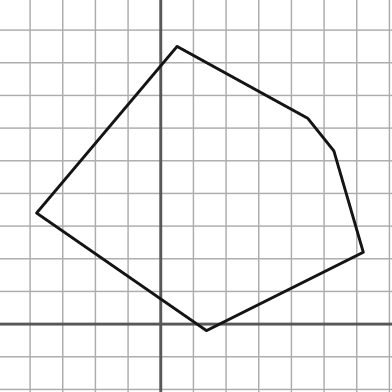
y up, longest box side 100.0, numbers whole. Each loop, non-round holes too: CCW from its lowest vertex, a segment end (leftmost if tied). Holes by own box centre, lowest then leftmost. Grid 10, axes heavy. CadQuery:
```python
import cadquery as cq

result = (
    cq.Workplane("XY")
    .moveTo(14.0, -2.0)
    .lineTo(62.0, 22.0)
    .lineTo(53.0, 53.0)
    .lineTo(45.0, 63.0)
    .lineTo(5.0, 85.0)
    .lineTo(-38.0, 34.0)
    .close()
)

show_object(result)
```